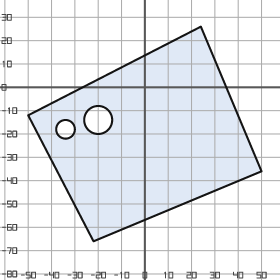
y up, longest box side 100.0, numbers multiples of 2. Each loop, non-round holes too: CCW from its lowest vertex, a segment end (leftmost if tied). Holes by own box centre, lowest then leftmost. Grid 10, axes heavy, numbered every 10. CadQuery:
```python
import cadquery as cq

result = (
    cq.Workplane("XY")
    .moveTo(-22.0, -66.0)
    .lineTo(50.0, -36.0)
    .lineTo(24.0, 26.0)
    .lineTo(-50.0, -12.0)
    .close()
    .moveTo(-34.0, -18.0)
    .circle(4.0)
    .moveTo(-20.0, -14.0)
    .circle(6.0)
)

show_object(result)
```